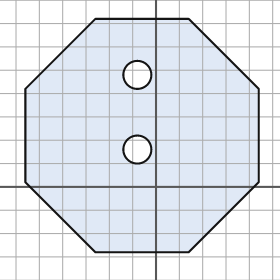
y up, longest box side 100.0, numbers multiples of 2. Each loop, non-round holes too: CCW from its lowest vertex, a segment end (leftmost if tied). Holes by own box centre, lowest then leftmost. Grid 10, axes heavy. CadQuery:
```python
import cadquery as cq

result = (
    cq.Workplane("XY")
    .moveTo(-26.0, -28.0)
    .lineTo(14.0, -28.0)
    .lineTo(44.0, 2.0)
    .lineTo(44.0, 42.0)
    .lineTo(14.0, 72.0)
    .lineTo(-26.0, 72.0)
    .lineTo(-56.0, 42.0)
    .lineTo(-56.0, 2.0)
    .close()
    .moveTo(-8.0, 16.0)
    .circle(6.0)
    .moveTo(-8.0, 48.0)
    .circle(6.0)
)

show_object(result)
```